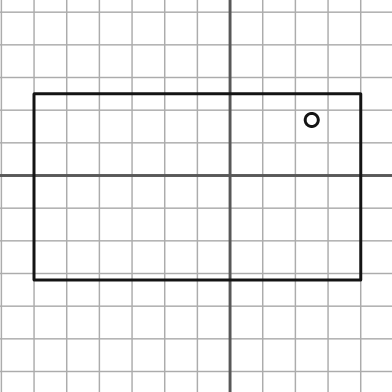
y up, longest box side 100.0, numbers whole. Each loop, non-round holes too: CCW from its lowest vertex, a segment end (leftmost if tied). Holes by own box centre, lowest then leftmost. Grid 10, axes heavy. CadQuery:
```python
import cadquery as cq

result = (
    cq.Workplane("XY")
    .moveTo(-60.0, -32.0)
    .lineTo(40.0, -32.0)
    .lineTo(40.0, 25.0)
    .lineTo(-60.0, 25.0)
    .close()
    .moveTo(25.0, 17.0)
    .circle(2.0)
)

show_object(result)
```